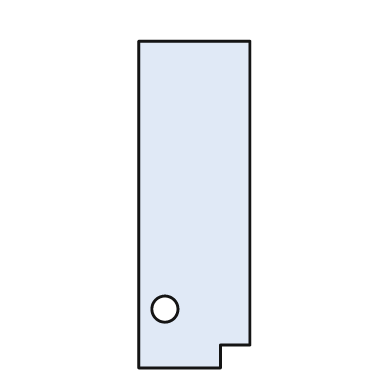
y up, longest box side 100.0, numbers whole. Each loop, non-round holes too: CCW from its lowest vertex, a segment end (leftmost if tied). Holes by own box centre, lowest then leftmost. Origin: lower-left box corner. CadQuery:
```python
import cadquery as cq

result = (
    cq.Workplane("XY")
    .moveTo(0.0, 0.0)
    .lineTo(25.0, 0.0)
    .lineTo(25.0, 7.0)
    .lineTo(34.0, 7.0)
    .lineTo(34.0, 100.0)
    .lineTo(0.0, 100.0)
    .close()
    .moveTo(8.0, 18.0)
    .circle(4.0)
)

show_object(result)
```